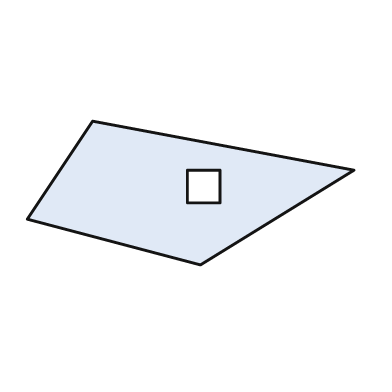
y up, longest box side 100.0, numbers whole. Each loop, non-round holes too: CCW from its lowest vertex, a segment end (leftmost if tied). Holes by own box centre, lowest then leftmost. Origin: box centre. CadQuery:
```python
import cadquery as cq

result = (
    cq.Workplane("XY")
    .moveTo(3.0, -22.0)
    .lineTo(50.0, 7.0)
    .lineTo(-30.0, 22.0)
    .lineTo(-50.0, -8.0)
    .close()
    .moveTo(-1.0, -3.0)
    .lineTo(9.0, -3.0)
    .lineTo(9.0, 7.0)
    .lineTo(-1.0, 7.0)
    .close()
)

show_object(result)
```